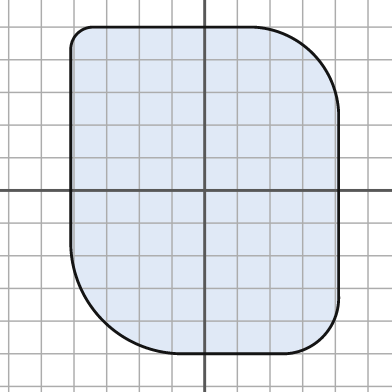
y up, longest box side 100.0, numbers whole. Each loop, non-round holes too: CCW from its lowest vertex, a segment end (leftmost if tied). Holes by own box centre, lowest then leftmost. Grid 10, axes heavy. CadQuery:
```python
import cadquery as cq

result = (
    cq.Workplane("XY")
    .moveTo(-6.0, -50.0)
    .lineTo(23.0, -50.0)
    .threePointArc((36.0, -45.0), (41.0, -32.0))
    .lineTo(41.0, 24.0)
    .threePointArc((33.0, 42.0), (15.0, 50.0))
    .lineTo(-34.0, 50.0)
    .threePointArc((-39.0, 48.0), (-41.0, 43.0))
    .lineTo(-41.0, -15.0)
    .threePointArc((-31.0, -40.0), (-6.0, -50.0))
    .close()
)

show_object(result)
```